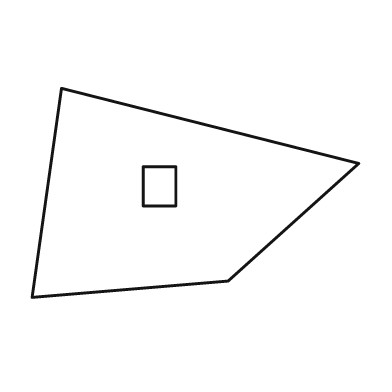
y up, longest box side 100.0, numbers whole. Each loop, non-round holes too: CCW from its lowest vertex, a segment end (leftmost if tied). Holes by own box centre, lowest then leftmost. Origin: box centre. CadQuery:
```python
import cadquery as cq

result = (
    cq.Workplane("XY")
    .moveTo(-50.0, -32.0)
    .lineTo(10.0, -27.0)
    .lineTo(50.0, 9.0)
    .lineTo(-41.0, 32.0)
    .close()
    .moveTo(-16.0, -4.0)
    .lineTo(-6.0, -4.0)
    .lineTo(-6.0, 8.0)
    .lineTo(-16.0, 8.0)
    .close()
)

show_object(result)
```